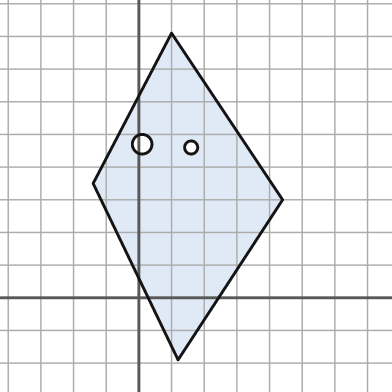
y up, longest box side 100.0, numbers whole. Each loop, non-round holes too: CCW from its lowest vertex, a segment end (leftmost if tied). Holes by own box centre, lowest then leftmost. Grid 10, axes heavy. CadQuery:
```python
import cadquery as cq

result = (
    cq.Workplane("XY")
    .moveTo(12.0, -19.0)
    .lineTo(44.0, 30.0)
    .lineTo(10.0, 81.0)
    .lineTo(-14.0, 35.0)
    .close()
    .moveTo(16.0, 46.0)
    .circle(2.0)
    .moveTo(1.0, 47.0)
    .circle(3.0)
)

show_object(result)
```